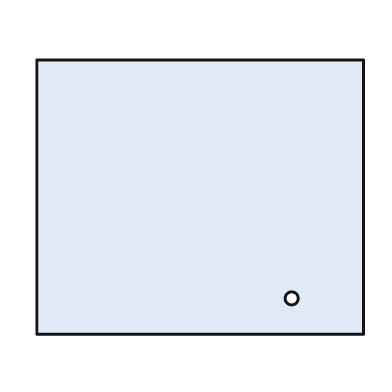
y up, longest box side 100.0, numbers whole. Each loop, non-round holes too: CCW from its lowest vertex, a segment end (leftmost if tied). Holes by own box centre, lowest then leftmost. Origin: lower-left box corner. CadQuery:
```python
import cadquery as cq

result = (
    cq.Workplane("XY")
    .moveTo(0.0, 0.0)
    .lineTo(100.0, 0.0)
    .lineTo(100.0, 84.0)
    .lineTo(0.0, 84.0)
    .close()
    .moveTo(78.0, 11.0)
    .circle(2.0)
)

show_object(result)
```